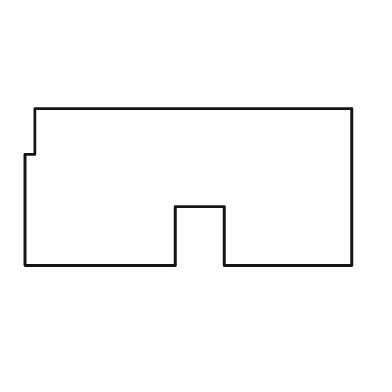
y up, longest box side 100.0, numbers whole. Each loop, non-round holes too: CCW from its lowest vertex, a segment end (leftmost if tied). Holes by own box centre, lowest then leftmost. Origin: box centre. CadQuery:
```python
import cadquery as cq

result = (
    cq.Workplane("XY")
    .moveTo(-50.0, -24.0)
    .lineTo(-4.0, -24.0)
    .lineTo(-4.0, -6.0)
    .lineTo(11.0, -6.0)
    .lineTo(11.0, -24.0)
    .lineTo(50.0, -24.0)
    .lineTo(50.0, 24.0)
    .lineTo(-47.0, 24.0)
    .lineTo(-47.0, 10.0)
    .lineTo(-50.0, 10.0)
    .close()
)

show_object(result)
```